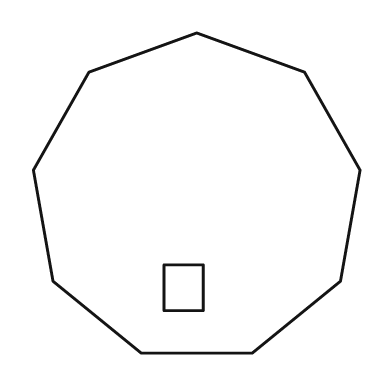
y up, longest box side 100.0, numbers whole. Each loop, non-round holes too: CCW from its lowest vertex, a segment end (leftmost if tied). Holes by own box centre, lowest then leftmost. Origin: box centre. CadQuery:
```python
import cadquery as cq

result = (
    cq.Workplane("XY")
    .moveTo(-17.0, -49.0)
    .lineTo(17.0, -49.0)
    .lineTo(44.0, -27.0)
    .lineTo(50.0, 7.0)
    .lineTo(33.0, 37.0)
    .lineTo(0.0, 49.0)
    .lineTo(-33.0, 37.0)
    .lineTo(-50.0, 7.0)
    .lineTo(-44.0, -27.0)
    .close()
    .moveTo(-10.0, -36.0)
    .lineTo(2.0, -36.0)
    .lineTo(2.0, -22.0)
    .lineTo(-10.0, -22.0)
    .close()
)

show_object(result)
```